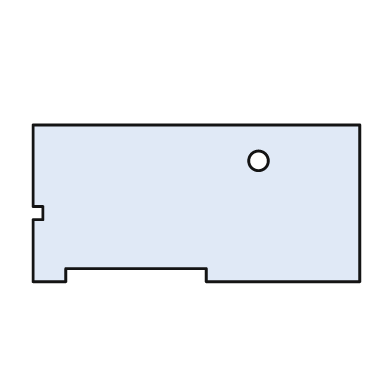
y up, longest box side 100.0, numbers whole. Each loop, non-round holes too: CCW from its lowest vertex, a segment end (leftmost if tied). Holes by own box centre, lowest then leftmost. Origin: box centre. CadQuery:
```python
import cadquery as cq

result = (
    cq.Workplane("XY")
    .moveTo(-50.0, -24.0)
    .lineTo(-40.0, -24.0)
    .lineTo(-40.0, -20.0)
    .lineTo(3.0, -20.0)
    .lineTo(3.0, -24.0)
    .lineTo(50.0, -24.0)
    .lineTo(50.0, 24.0)
    .lineTo(-50.0, 24.0)
    .lineTo(-50.0, -1.0)
    .lineTo(-47.0, -1.0)
    .lineTo(-47.0, -5.0)
    .lineTo(-50.0, -5.0)
    .close()
    .moveTo(19.0, 13.0)
    .circle(3.0)
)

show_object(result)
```